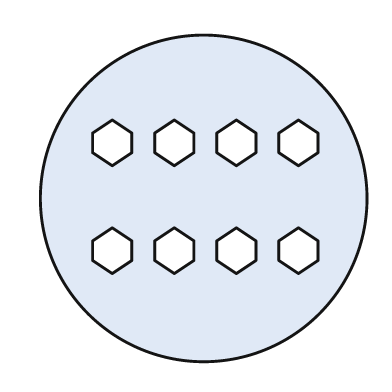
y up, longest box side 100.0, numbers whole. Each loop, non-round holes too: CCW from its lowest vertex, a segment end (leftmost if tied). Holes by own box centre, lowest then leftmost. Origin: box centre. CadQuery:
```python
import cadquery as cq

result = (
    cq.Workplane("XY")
    .moveTo(0.0, 0.0)
    .circle(50.0)
    .moveTo(-28.0, -23.0)
    .lineTo(-22.0, -19.0)
    .lineTo(-22.0, -13.0)
    .lineTo(-28.0, -9.0)
    .lineTo(-34.0, -13.0)
    .lineTo(-34.0, -19.0)
    .close()
    .moveTo(-9.0, -23.0)
    .lineTo(-3.0, -19.0)
    .lineTo(-3.0, -13.0)
    .lineTo(-9.0, -9.0)
    .lineTo(-15.0, -13.0)
    .lineTo(-15.0, -19.0)
    .close()
    .moveTo(10.0, -23.0)
    .lineTo(16.0, -19.0)
    .lineTo(16.0, -13.0)
    .lineTo(10.0, -9.0)
    .lineTo(4.0, -13.0)
    .lineTo(4.0, -19.0)
    .close()
    .moveTo(29.0, -23.0)
    .lineTo(35.0, -19.0)
    .lineTo(35.0, -13.0)
    .lineTo(29.0, -9.0)
    .lineTo(23.0, -13.0)
    .lineTo(23.0, -19.0)
    .close()
    .moveTo(-28.0, 10.0)
    .lineTo(-22.0, 14.0)
    .lineTo(-22.0, 20.0)
    .lineTo(-28.0, 24.0)
    .lineTo(-34.0, 20.0)
    .lineTo(-34.0, 14.0)
    .close()
    .moveTo(-9.0, 10.0)
    .lineTo(-3.0, 14.0)
    .lineTo(-3.0, 20.0)
    .lineTo(-9.0, 24.0)
    .lineTo(-15.0, 20.0)
    .lineTo(-15.0, 14.0)
    .close()
    .moveTo(10.0, 10.0)
    .lineTo(16.0, 14.0)
    .lineTo(16.0, 20.0)
    .lineTo(10.0, 24.0)
    .lineTo(4.0, 20.0)
    .lineTo(4.0, 14.0)
    .close()
    .moveTo(29.0, 10.0)
    .lineTo(35.0, 14.0)
    .lineTo(35.0, 20.0)
    .lineTo(29.0, 24.0)
    .lineTo(23.0, 20.0)
    .lineTo(23.0, 14.0)
    .close()
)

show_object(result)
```